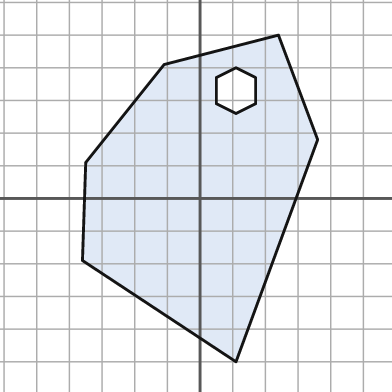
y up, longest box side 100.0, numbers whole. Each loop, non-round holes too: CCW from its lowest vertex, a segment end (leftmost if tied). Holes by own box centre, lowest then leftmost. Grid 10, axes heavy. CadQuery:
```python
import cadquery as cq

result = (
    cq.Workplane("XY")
    .moveTo(11.0, -50.0)
    .lineTo(36.0, 18.0)
    .lineTo(24.0, 50.0)
    .lineTo(-11.0, 41.0)
    .lineTo(-35.0, 11.0)
    .lineTo(-36.0, -19.0)
    .close()
    .moveTo(11.0, 26.0)
    .lineTo(17.0, 29.0)
    .lineTo(17.0, 37.0)
    .lineTo(11.0, 40.0)
    .lineTo(5.0, 37.0)
    .lineTo(5.0, 29.0)
    .close()
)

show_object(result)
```